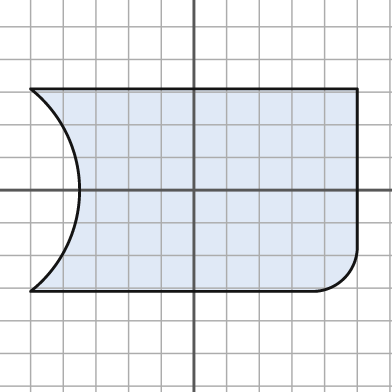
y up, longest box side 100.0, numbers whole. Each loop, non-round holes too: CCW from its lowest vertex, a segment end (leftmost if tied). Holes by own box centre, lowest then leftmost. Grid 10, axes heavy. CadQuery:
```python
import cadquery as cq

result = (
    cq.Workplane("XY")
    .moveTo(-50.0, -31.0)
    .lineTo(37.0, -31.0)
    .threePointArc((46.0, -27.0), (50.0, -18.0))
    .lineTo(50.0, 31.0)
    .lineTo(-50.0, 31.0)
    .threePointArc((-35.0, 0.0), (-50.0, -31.0))
    .close()
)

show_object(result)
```